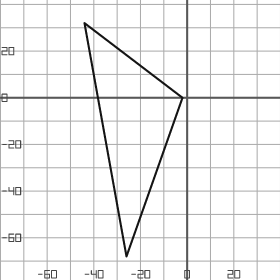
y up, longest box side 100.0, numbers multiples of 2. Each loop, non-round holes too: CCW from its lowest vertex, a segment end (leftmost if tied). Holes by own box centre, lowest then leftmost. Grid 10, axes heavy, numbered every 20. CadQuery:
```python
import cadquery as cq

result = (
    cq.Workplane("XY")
    .moveTo(-26.0, -68.0)
    .lineTo(-2.0, 0.0)
    .lineTo(-44.0, 32.0)
    .close()
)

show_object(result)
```